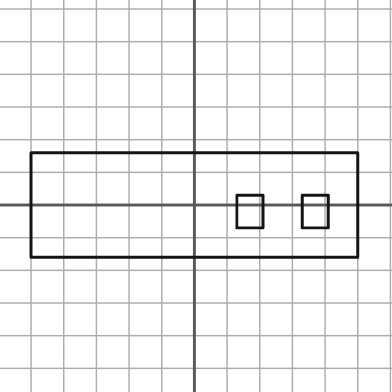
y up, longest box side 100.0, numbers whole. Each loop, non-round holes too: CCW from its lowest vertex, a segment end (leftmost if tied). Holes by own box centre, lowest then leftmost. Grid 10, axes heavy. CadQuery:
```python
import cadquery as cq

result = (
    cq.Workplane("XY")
    .moveTo(-50.0, -16.0)
    .lineTo(50.0, -16.0)
    .lineTo(50.0, 16.0)
    .lineTo(-50.0, 16.0)
    .close()
    .moveTo(13.0, -7.0)
    .lineTo(21.0, -7.0)
    .lineTo(21.0, 3.0)
    .lineTo(13.0, 3.0)
    .close()
    .moveTo(33.0, -7.0)
    .lineTo(41.0, -7.0)
    .lineTo(41.0, 3.0)
    .lineTo(33.0, 3.0)
    .close()
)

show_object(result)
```